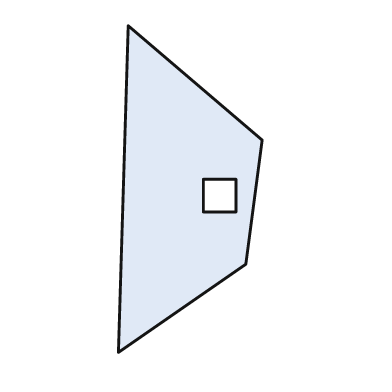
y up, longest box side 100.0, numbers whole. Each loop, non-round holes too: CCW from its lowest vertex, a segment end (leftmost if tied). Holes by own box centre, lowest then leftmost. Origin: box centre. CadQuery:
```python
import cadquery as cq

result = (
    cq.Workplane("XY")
    .moveTo(-22.0, -50.0)
    .lineTo(17.0, -23.0)
    .lineTo(22.0, 15.0)
    .lineTo(-19.0, 50.0)
    .close()
    .moveTo(4.0, -7.0)
    .lineTo(14.0, -7.0)
    .lineTo(14.0, 3.0)
    .lineTo(4.0, 3.0)
    .close()
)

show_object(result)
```